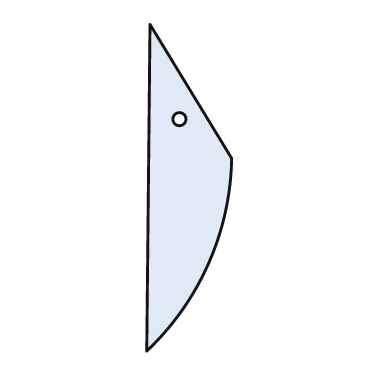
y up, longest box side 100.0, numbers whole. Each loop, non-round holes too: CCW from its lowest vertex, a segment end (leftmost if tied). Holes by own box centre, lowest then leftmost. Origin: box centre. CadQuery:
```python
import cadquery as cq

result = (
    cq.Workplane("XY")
    .moveTo(-13.0, -50.0)
    .threePointArc((6.0, -23.0), (13.0, 9.0))
    .lineTo(-12.0, 50.0)
    .close()
    .moveTo(-3.0, 21.0)
    .circle(2.0)
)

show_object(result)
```